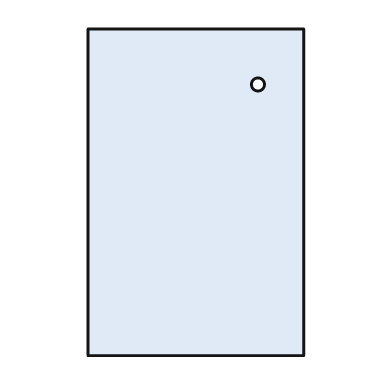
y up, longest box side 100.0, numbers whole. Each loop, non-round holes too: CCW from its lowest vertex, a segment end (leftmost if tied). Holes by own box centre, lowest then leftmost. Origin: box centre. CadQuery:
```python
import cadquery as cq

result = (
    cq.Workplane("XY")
    .moveTo(-33.0, -50.0)
    .lineTo(33.0, -50.0)
    .lineTo(33.0, 50.0)
    .lineTo(-33.0, 50.0)
    .close()
    .moveTo(19.0, 33.0)
    .circle(2.0)
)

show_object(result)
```